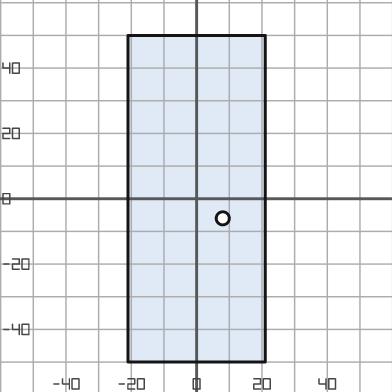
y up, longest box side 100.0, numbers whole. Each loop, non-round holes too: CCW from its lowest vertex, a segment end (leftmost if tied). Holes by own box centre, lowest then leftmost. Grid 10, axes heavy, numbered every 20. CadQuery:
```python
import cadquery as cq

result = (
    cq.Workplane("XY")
    .moveTo(-21.0, -50.0)
    .lineTo(21.0, -50.0)
    .lineTo(21.0, 50.0)
    .lineTo(-21.0, 50.0)
    .close()
    .moveTo(8.0, -6.0)
    .circle(2.0)
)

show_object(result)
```